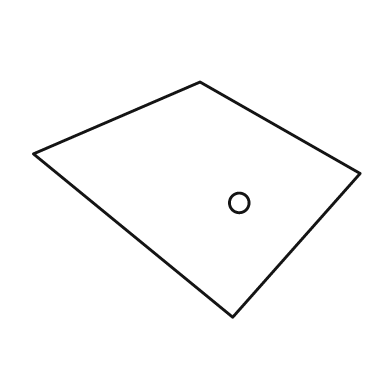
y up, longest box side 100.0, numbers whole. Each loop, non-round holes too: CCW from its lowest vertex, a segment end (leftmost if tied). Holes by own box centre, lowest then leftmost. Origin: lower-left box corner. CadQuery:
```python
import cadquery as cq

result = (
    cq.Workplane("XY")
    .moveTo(61.0, 0.0)
    .lineTo(100.0, 44.0)
    .lineTo(51.0, 72.0)
    .lineTo(0.0, 50.0)
    .close()
    .moveTo(63.0, 35.0)
    .circle(3.0)
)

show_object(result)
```